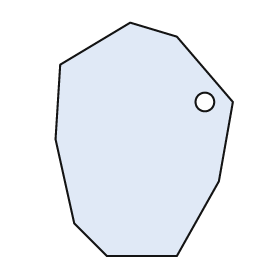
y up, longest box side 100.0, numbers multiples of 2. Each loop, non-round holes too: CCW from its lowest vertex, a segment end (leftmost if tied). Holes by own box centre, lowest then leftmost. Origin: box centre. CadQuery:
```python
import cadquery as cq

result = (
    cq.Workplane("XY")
    .moveTo(-16.0, -50.0)
    .lineTo(14.0, -50.0)
    .lineTo(32.0, -18.0)
    .lineTo(38.0, 16.0)
    .lineTo(14.0, 44.0)
    .lineTo(-6.0, 50.0)
    .lineTo(-36.0, 32.0)
    .lineTo(-38.0, 0.0)
    .lineTo(-30.0, -36.0)
    .close()
    .moveTo(26.0, 16.0)
    .circle(4.0)
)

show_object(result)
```